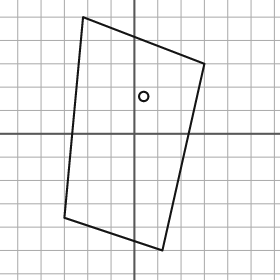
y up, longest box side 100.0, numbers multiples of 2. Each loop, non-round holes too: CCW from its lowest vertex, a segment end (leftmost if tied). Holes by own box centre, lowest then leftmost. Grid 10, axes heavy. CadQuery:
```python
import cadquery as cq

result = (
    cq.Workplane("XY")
    .moveTo(12.0, -50.0)
    .lineTo(30.0, 30.0)
    .lineTo(-22.0, 50.0)
    .lineTo(-30.0, -36.0)
    .close()
    .moveTo(4.0, 16.0)
    .circle(2.0)
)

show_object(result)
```